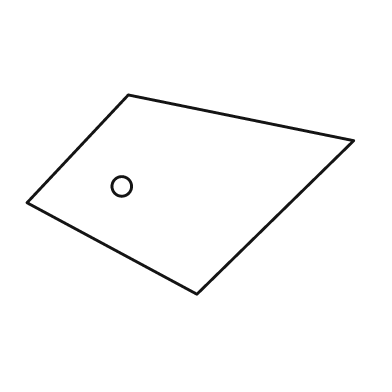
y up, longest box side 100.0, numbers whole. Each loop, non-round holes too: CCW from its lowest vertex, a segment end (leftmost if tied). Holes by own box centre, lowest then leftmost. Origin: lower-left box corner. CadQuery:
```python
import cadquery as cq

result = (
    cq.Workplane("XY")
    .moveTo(52.0, 0.0)
    .lineTo(100.0, 47.0)
    .lineTo(31.0, 61.0)
    .lineTo(0.0, 28.0)
    .close()
    .moveTo(29.0, 33.0)
    .circle(3.0)
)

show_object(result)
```